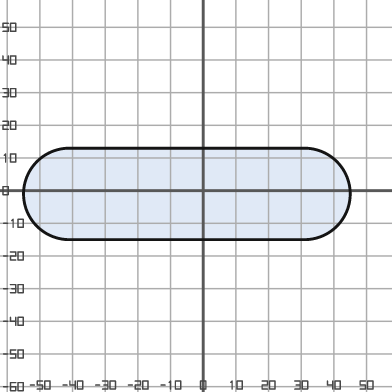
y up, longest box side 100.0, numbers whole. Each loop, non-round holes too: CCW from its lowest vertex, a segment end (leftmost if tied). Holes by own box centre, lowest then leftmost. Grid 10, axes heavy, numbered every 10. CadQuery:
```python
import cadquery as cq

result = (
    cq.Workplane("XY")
    .moveTo(-41.0, -15.0)
    .lineTo(31.0, -15.0)
    .threePointArc((45.0, -1.0), (31.0, 13.0))
    .lineTo(-41.0, 13.0)
    .threePointArc((-55.0, -1.0), (-41.0, -15.0))
    .close()
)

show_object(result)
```